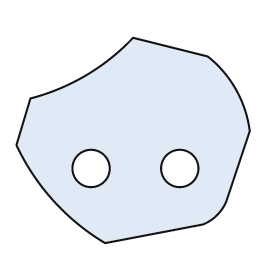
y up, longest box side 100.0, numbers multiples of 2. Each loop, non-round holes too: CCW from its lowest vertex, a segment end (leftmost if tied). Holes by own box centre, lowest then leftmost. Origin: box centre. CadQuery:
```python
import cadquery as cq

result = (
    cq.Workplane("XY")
    .moveTo(-12.0, -44.0)
    .lineTo(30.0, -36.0)
    .threePointArc((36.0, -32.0), (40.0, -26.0))
    .lineTo(50.0, 4.0)
    .threePointArc((44.0, 22.0), (32.0, 36.0))
    .lineTo(0.0, 44.0)
    .threePointArc((-20.0, 28.0), (-44.0, 18.0))
    .lineTo(-50.0, -2.0)
    .threePointArc((-34.0, -26.0), (-12.0, -44.0))
    .close()
    .moveTo(-18.0, -12.0)
    .circle(8.0)
    .moveTo(20.0, -12.0)
    .circle(8.0)
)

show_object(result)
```